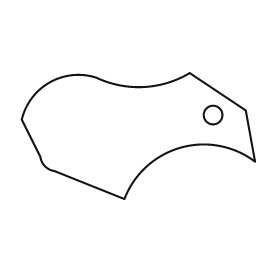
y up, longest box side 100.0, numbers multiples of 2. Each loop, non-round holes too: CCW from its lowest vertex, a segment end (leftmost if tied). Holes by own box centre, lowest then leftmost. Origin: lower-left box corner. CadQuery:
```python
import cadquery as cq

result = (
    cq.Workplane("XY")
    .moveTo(44.0, 0.0)
    .threePointArc((68.0, 22.0), (100.0, 16.0))
    .lineTo(96.0, 38.0)
    .lineTo(72.0, 54.0)
    .threePointArc((52.0, 48.0), (32.0, 52.0))
    .threePointArc((12.0, 50.0), (0.0, 34.0))
    .lineTo(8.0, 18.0)
    .threePointArc((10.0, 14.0), (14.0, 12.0))
    .close()
    .moveTo(82.0, 36.0)
    .circle(4.0)
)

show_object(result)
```